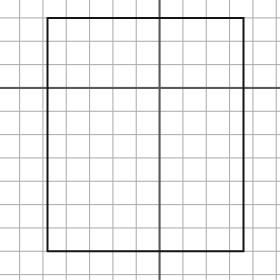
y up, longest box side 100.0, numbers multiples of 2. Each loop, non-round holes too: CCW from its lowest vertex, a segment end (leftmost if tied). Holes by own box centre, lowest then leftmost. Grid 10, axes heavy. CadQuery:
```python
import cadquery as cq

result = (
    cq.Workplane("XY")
    .moveTo(-48.0, -70.0)
    .lineTo(36.0, -70.0)
    .lineTo(36.0, 30.0)
    .lineTo(-48.0, 30.0)
    .close()
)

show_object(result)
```